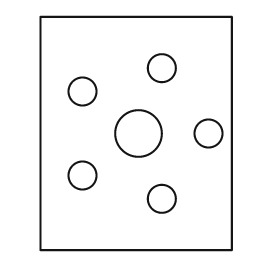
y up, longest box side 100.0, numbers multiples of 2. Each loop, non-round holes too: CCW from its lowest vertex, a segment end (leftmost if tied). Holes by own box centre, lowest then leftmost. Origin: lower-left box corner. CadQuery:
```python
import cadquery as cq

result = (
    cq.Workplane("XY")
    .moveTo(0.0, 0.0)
    .lineTo(82.0, 0.0)
    .lineTo(82.0, 100.0)
    .lineTo(0.0, 100.0)
    .close()
    .moveTo(52.0, 22.0)
    .circle(6.0)
    .moveTo(18.0, 32.0)
    .circle(6.0)
    .moveTo(42.0, 50.0)
    .circle(10.0)
    .moveTo(72.0, 50.0)
    .circle(6.0)
    .moveTo(18.0, 68.0)
    .circle(6.0)
    .moveTo(52.0, 78.0)
    .circle(6.0)
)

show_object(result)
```